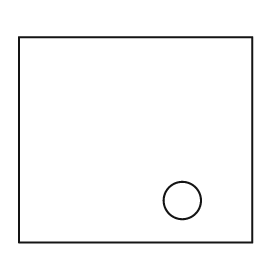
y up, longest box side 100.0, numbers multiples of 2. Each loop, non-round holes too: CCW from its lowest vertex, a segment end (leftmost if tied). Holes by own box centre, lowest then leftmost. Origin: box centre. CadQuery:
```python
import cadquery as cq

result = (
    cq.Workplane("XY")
    .moveTo(-50.0, -44.0)
    .lineTo(50.0, -44.0)
    .lineTo(50.0, 44.0)
    .lineTo(-50.0, 44.0)
    .close()
    .moveTo(20.0, -26.0)
    .circle(8.0)
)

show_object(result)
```